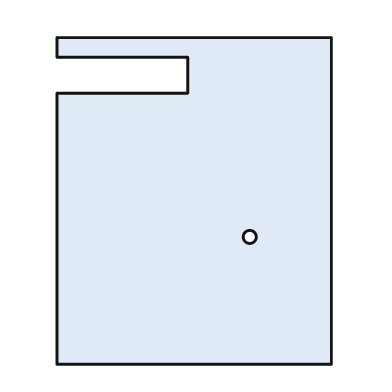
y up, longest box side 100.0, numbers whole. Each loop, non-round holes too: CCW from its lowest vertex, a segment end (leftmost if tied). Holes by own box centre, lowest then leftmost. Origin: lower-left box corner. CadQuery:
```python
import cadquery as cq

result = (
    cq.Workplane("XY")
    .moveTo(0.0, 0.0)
    .lineTo(84.0, 0.0)
    .lineTo(84.0, 100.0)
    .lineTo(0.0, 100.0)
    .lineTo(0.0, 94.0)
    .lineTo(40.0, 94.0)
    .lineTo(40.0, 83.0)
    .lineTo(0.0, 83.0)
    .close()
    .moveTo(59.0, 39.0)
    .circle(2.0)
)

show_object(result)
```